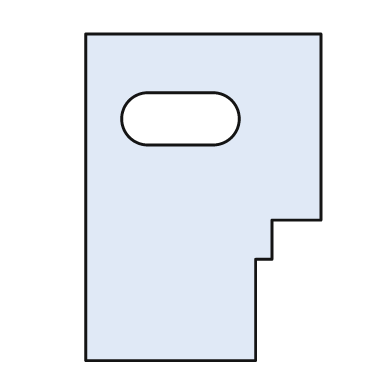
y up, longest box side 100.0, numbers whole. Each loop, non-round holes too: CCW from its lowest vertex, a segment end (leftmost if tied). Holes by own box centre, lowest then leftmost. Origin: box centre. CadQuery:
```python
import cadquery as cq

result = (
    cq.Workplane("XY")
    .moveTo(-36.0, -50.0)
    .lineTo(16.0, -50.0)
    .lineTo(16.0, -19.0)
    .lineTo(21.0, -19.0)
    .lineTo(21.0, -7.0)
    .lineTo(36.0, -7.0)
    .lineTo(36.0, 50.0)
    .lineTo(-36.0, 50.0)
    .close()
    .moveTo(-17.0, 16.0)
    .lineTo(3.0, 16.0)
    .threePointArc((11.0, 24.0), (3.0, 32.0))
    .lineTo(-17.0, 32.0)
    .threePointArc((-25.0, 24.0), (-17.0, 16.0))
    .close()
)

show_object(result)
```